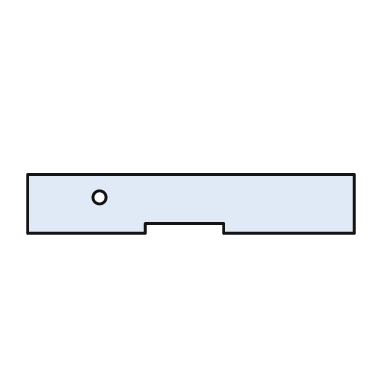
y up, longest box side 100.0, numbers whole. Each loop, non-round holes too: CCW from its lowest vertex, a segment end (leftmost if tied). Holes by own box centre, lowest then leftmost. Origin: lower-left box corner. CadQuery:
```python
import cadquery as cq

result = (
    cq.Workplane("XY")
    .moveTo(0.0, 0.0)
    .lineTo(36.0, 0.0)
    .lineTo(36.0, 3.0)
    .lineTo(60.0, 3.0)
    .lineTo(60.0, 0.0)
    .lineTo(100.0, 0.0)
    .lineTo(100.0, 18.0)
    .lineTo(0.0, 18.0)
    .close()
    .moveTo(22.0, 11.0)
    .circle(2.0)
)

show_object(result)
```